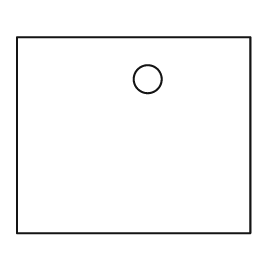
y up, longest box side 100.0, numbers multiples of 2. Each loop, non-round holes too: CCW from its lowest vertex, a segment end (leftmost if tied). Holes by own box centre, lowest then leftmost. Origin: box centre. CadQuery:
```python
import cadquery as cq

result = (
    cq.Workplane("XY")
    .moveTo(-50.0, -42.0)
    .lineTo(50.0, -42.0)
    .lineTo(50.0, 42.0)
    .lineTo(-50.0, 42.0)
    .close()
    .moveTo(6.0, 24.0)
    .circle(6.0)
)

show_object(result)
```